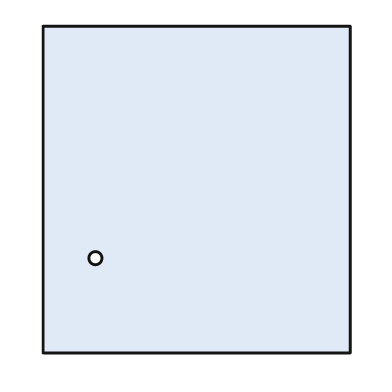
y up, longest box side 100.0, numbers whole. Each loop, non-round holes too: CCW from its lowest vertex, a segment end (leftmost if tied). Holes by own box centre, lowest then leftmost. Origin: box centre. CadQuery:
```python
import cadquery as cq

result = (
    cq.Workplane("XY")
    .moveTo(-47.0, -50.0)
    .lineTo(47.0, -50.0)
    .lineTo(47.0, 50.0)
    .lineTo(-47.0, 50.0)
    .close()
    .moveTo(-31.0, -21.0)
    .circle(2.0)
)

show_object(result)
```